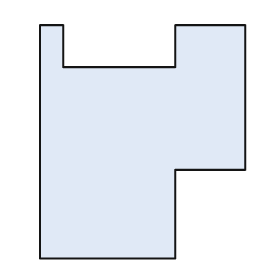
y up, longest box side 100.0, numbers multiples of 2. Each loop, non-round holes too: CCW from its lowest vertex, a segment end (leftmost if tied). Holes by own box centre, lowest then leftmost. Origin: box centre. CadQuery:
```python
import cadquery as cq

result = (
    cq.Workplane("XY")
    .moveTo(-44.0, -50.0)
    .lineTo(14.0, -50.0)
    .lineTo(14.0, -12.0)
    .lineTo(44.0, -12.0)
    .lineTo(44.0, 50.0)
    .lineTo(14.0, 50.0)
    .lineTo(14.0, 32.0)
    .lineTo(-34.0, 32.0)
    .lineTo(-34.0, 50.0)
    .lineTo(-44.0, 50.0)
    .close()
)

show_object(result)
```